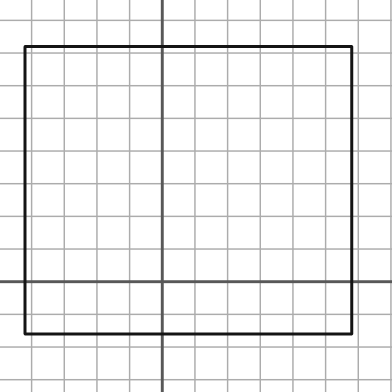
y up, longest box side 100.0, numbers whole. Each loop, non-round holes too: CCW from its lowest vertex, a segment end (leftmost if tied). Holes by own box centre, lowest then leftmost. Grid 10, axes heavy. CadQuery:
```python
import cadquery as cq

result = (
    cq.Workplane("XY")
    .moveTo(-42.0, -16.0)
    .lineTo(58.0, -16.0)
    .lineTo(58.0, 72.0)
    .lineTo(-42.0, 72.0)
    .close()
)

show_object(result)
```